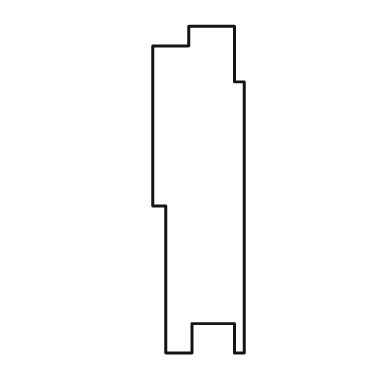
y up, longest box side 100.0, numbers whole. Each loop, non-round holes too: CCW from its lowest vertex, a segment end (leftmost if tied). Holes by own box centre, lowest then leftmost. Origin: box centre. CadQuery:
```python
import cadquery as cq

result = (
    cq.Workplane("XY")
    .moveTo(-10.0, -50.0)
    .lineTo(-2.0, -50.0)
    .lineTo(-2.0, -41.0)
    .lineTo(11.0, -41.0)
    .lineTo(11.0, -50.0)
    .lineTo(14.0, -50.0)
    .lineTo(14.0, 33.0)
    .lineTo(11.0, 33.0)
    .lineTo(11.0, 50.0)
    .lineTo(-3.0, 50.0)
    .lineTo(-3.0, 44.0)
    .lineTo(-14.0, 44.0)
    .lineTo(-14.0, -5.0)
    .lineTo(-10.0, -5.0)
    .close()
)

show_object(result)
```